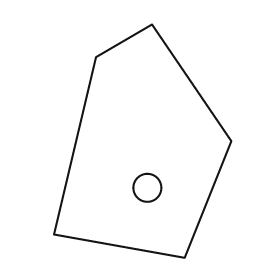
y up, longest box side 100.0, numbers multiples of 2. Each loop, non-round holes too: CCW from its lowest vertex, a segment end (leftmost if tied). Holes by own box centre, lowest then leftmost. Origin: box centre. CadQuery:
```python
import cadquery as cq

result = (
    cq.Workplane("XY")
    .moveTo(18.0, -50.0)
    .lineTo(38.0, 0.0)
    .lineTo(4.0, 50.0)
    .lineTo(-20.0, 36.0)
    .lineTo(-38.0, -40.0)
    .close()
    .moveTo(2.0, -20.0)
    .circle(6.0)
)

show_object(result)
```